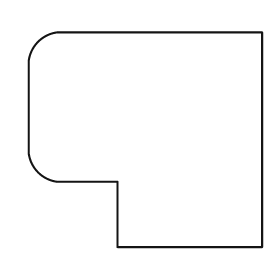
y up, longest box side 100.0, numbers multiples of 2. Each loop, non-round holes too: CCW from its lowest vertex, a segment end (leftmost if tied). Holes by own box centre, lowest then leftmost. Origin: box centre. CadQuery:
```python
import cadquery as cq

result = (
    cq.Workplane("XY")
    .moveTo(-12.0, -46.0)
    .lineTo(50.0, -46.0)
    .lineTo(50.0, 46.0)
    .lineTo(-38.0, 46.0)
    .threePointArc((-46.0, 42.0), (-50.0, 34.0))
    .lineTo(-50.0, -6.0)
    .threePointArc((-46.0, -14.0), (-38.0, -18.0))
    .lineTo(-12.0, -18.0)
    .close()
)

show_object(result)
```